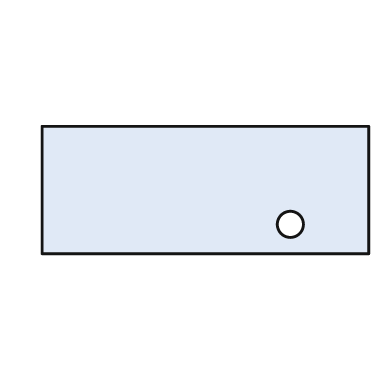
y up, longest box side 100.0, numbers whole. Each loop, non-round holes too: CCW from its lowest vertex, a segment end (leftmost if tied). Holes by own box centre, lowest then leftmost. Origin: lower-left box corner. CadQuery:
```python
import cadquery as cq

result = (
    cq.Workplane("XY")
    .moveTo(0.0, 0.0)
    .lineTo(100.0, 0.0)
    .lineTo(100.0, 39.0)
    .lineTo(0.0, 39.0)
    .close()
    .moveTo(76.0, 9.0)
    .circle(4.0)
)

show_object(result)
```